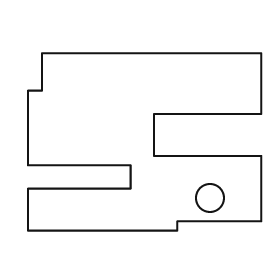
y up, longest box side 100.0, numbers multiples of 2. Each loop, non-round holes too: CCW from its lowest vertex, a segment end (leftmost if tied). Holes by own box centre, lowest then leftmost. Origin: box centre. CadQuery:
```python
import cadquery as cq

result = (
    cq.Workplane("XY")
    .moveTo(-50.0, -38.0)
    .lineTo(14.0, -38.0)
    .lineTo(14.0, -34.0)
    .lineTo(50.0, -34.0)
    .lineTo(50.0, -6.0)
    .lineTo(4.0, -6.0)
    .lineTo(4.0, 12.0)
    .lineTo(50.0, 12.0)
    .lineTo(50.0, 38.0)
    .lineTo(-44.0, 38.0)
    .lineTo(-44.0, 22.0)
    .lineTo(-50.0, 22.0)
    .lineTo(-50.0, -10.0)
    .lineTo(-6.0, -10.0)
    .lineTo(-6.0, -20.0)
    .lineTo(-50.0, -20.0)
    .close()
    .moveTo(28.0, -24.0)
    .circle(6.0)
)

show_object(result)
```